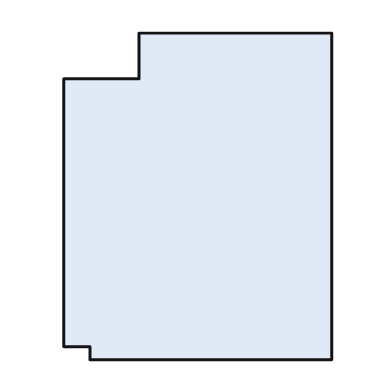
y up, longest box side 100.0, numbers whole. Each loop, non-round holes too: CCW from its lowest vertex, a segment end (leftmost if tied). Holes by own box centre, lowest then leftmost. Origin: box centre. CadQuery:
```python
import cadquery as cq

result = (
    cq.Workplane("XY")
    .moveTo(-33.0, -50.0)
    .lineTo(41.0, -50.0)
    .lineTo(41.0, 50.0)
    .lineTo(-18.0, 50.0)
    .lineTo(-18.0, 36.0)
    .lineTo(-41.0, 36.0)
    .lineTo(-41.0, -46.0)
    .lineTo(-33.0, -46.0)
    .close()
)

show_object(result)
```